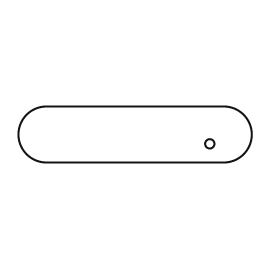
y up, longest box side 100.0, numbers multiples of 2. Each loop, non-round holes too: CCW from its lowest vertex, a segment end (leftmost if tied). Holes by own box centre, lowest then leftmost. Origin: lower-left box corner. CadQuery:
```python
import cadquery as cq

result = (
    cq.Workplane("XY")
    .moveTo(12.0, 0.0)
    .lineTo(88.0, 0.0)
    .threePointArc((100.0, 12.0), (88.0, 24.0))
    .lineTo(12.0, 24.0)
    .threePointArc((0.0, 12.0), (12.0, 0.0))
    .close()
    .moveTo(82.0, 8.0)
    .circle(2.0)
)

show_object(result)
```